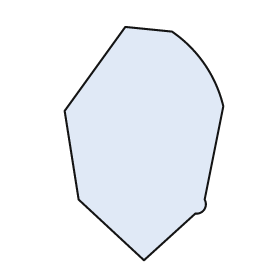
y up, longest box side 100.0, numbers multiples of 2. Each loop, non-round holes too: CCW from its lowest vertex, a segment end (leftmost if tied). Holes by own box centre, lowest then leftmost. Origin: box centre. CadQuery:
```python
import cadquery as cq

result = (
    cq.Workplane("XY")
    .moveTo(0.0, -50.0)
    .lineTo(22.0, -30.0)
    .threePointArc((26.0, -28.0), (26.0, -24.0))
    .lineTo(34.0, 16.0)
    .threePointArc((26.0, 34.0), (12.0, 48.0))
    .lineTo(-8.0, 50.0)
    .lineTo(-34.0, 14.0)
    .lineTo(-28.0, -24.0)
    .close()
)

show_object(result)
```